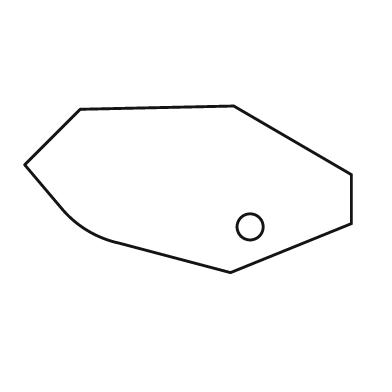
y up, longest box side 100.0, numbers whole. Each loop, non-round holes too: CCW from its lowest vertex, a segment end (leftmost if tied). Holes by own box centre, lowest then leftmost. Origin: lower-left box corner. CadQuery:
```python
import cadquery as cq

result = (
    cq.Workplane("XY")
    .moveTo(63.0, 0.0)
    .lineTo(100.0, 15.0)
    .lineTo(100.0, 30.0)
    .lineTo(64.0, 51.0)
    .lineTo(17.0, 50.0)
    .lineTo(0.0, 33.0)
    .lineTo(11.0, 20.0)
    .threePointArc((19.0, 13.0), (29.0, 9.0))
    .close()
    .moveTo(69.0, 14.0)
    .circle(4.0)
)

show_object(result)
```